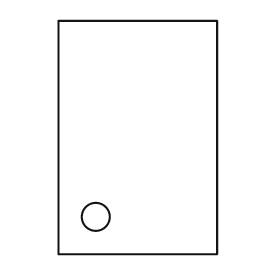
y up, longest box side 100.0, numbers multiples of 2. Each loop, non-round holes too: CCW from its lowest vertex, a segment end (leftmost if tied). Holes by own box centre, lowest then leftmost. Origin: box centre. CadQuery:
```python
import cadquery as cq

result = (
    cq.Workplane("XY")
    .moveTo(-34.0, -50.0)
    .lineTo(34.0, -50.0)
    .lineTo(34.0, 50.0)
    .lineTo(-34.0, 50.0)
    .close()
    .moveTo(-18.0, -34.0)
    .circle(6.0)
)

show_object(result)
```